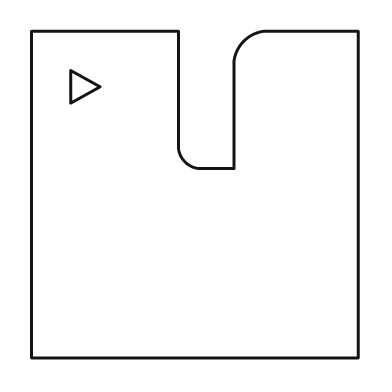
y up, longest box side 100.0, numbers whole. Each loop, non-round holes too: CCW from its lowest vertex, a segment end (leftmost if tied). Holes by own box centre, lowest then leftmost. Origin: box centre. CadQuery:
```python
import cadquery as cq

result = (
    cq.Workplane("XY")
    .moveTo(-50.0, -50.0)
    .lineTo(50.0, -50.0)
    .lineTo(50.0, 50.0)
    .lineTo(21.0, 50.0)
    .threePointArc((15.0, 47.0), (12.0, 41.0))
    .lineTo(12.0, 8.0)
    .lineTo(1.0, 8.0)
    .threePointArc((-3.0, 10.0), (-5.0, 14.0))
    .lineTo(-5.0, 50.0)
    .lineTo(-50.0, 50.0)
    .close()
    .moveTo(-38.0, 28.0)
    .lineTo(-29.0, 33.0)
    .lineTo(-38.0, 38.0)
    .close()
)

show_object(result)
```